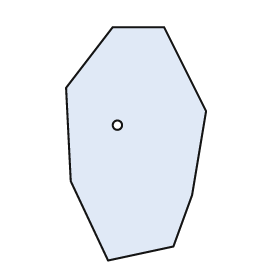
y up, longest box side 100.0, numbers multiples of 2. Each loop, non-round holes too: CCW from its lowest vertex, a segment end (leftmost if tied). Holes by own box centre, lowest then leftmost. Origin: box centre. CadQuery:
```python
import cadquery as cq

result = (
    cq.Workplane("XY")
    .moveTo(-12.0, -50.0)
    .lineTo(16.0, -44.0)
    .lineTo(24.0, -22.0)
    .lineTo(30.0, 14.0)
    .lineTo(12.0, 50.0)
    .lineTo(-10.0, 50.0)
    .lineTo(-30.0, 24.0)
    .lineTo(-28.0, -16.0)
    .close()
    .moveTo(-8.0, 8.0)
    .circle(2.0)
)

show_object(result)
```